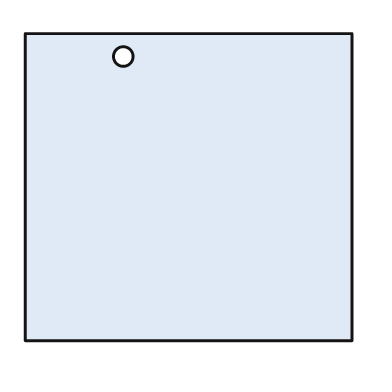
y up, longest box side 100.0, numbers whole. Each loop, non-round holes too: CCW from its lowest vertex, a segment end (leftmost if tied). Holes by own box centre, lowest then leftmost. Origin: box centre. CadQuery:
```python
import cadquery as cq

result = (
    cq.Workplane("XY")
    .moveTo(-50.0, -47.0)
    .lineTo(50.0, -47.0)
    .lineTo(50.0, 47.0)
    .lineTo(-50.0, 47.0)
    .close()
    .moveTo(-20.0, 40.0)
    .circle(3.0)
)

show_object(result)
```